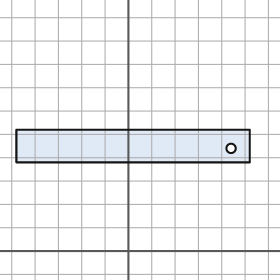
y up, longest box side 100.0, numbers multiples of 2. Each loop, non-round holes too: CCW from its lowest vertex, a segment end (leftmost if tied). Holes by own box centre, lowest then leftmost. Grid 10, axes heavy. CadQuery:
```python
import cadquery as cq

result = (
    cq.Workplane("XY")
    .moveTo(-48.0, 38.0)
    .lineTo(52.0, 38.0)
    .lineTo(52.0, 52.0)
    .lineTo(-48.0, 52.0)
    .close()
    .moveTo(44.0, 44.0)
    .circle(2.0)
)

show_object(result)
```